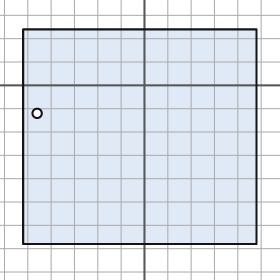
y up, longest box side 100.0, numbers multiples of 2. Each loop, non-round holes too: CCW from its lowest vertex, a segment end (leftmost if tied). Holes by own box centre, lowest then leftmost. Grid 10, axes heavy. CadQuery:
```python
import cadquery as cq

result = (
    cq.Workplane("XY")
    .moveTo(-52.0, -68.0)
    .lineTo(48.0, -68.0)
    .lineTo(48.0, 24.0)
    .lineTo(-52.0, 24.0)
    .close()
    .moveTo(-46.0, -12.0)
    .circle(2.0)
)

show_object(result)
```